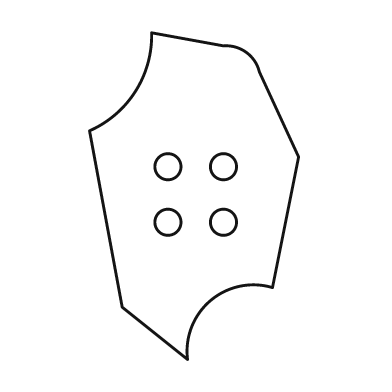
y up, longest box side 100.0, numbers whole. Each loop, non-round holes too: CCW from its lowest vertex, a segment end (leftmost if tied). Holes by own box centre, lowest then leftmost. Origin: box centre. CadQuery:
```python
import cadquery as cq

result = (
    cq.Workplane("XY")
    .moveTo(-2.0, -50.0)
    .threePointArc((5.0, -32.0), (24.0, -28.0))
    .lineTo(32.0, 12.0)
    .lineTo(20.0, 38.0)
    .threePointArc((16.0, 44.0), (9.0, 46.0))
    .lineTo(-13.0, 50.0)
    .threePointArc((-18.0, 32.0), (-32.0, 20.0))
    .lineTo(-22.0, -34.0)
    .close()
    .moveTo(-8.0, -8.0)
    .circle(4.0)
    .moveTo(9.0, -8.0)
    .circle(4.0)
    .moveTo(-8.0, 9.0)
    .circle(4.0)
    .moveTo(9.0, 9.0)
    .circle(4.0)
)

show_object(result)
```